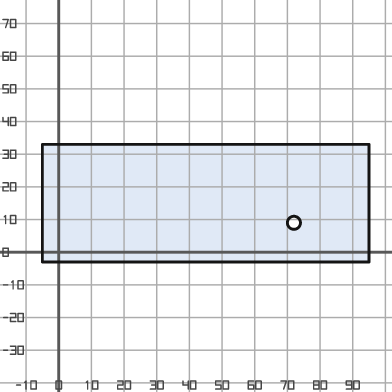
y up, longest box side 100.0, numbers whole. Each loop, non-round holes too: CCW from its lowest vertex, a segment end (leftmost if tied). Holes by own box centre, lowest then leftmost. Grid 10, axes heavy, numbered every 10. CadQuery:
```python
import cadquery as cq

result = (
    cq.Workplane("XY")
    .moveTo(-5.0, -3.0)
    .lineTo(95.0, -3.0)
    .lineTo(95.0, 33.0)
    .lineTo(-5.0, 33.0)
    .close()
    .moveTo(72.0, 9.0)
    .circle(2.0)
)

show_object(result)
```